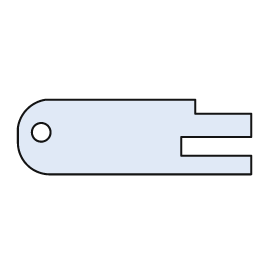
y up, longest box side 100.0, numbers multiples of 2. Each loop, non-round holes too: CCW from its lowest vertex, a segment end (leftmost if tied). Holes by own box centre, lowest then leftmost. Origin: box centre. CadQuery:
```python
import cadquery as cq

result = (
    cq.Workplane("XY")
    .moveTo(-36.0, -16.0)
    .lineTo(50.0, -16.0)
    .lineTo(50.0, -8.0)
    .lineTo(20.0, -8.0)
    .lineTo(20.0, 0.0)
    .lineTo(50.0, 0.0)
    .lineTo(50.0, 10.0)
    .lineTo(26.0, 10.0)
    .lineTo(26.0, 16.0)
    .lineTo(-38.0, 16.0)
    .threePointArc((-46.0, 12.0), (-50.0, 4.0))
    .lineTo(-50.0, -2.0)
    .threePointArc((-46.0, -12.0), (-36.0, -16.0))
    .close()
    .moveTo(-40.0, 2.0)
    .circle(4.0)
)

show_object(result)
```